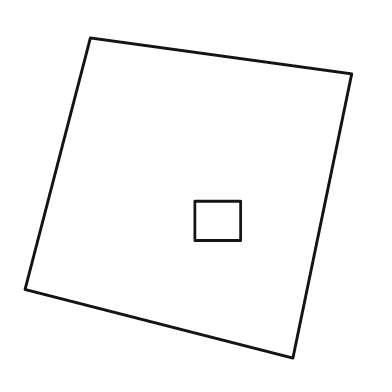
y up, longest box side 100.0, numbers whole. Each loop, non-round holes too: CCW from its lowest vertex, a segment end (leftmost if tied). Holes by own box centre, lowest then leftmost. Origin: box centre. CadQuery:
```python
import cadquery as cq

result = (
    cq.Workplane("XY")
    .moveTo(32.0, -49.0)
    .lineTo(50.0, 38.0)
    .lineTo(-30.0, 49.0)
    .lineTo(-50.0, -28.0)
    .close()
    .moveTo(2.0, -13.0)
    .lineTo(16.0, -13.0)
    .lineTo(16.0, -1.0)
    .lineTo(2.0, -1.0)
    .close()
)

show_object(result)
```